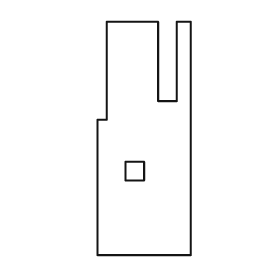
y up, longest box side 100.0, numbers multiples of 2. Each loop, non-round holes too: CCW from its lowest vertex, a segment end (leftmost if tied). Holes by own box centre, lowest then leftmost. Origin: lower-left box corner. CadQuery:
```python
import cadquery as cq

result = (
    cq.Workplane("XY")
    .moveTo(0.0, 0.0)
    .lineTo(40.0, 0.0)
    .lineTo(40.0, 100.0)
    .lineTo(34.0, 100.0)
    .lineTo(34.0, 66.0)
    .lineTo(26.0, 66.0)
    .lineTo(26.0, 100.0)
    .lineTo(4.0, 100.0)
    .lineTo(4.0, 58.0)
    .lineTo(0.0, 58.0)
    .close()
    .moveTo(12.0, 32.0)
    .lineTo(20.0, 32.0)
    .lineTo(20.0, 40.0)
    .lineTo(12.0, 40.0)
    .close()
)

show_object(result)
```